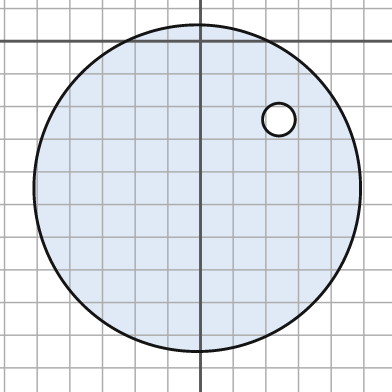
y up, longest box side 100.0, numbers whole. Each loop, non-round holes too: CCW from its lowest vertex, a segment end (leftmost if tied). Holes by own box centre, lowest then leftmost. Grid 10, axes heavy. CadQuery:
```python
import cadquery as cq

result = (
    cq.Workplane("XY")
    .moveTo(-1.0, -45.0)
    .circle(50.0)
    .moveTo(24.0, -24.0)
    .circle(5.0)
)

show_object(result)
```